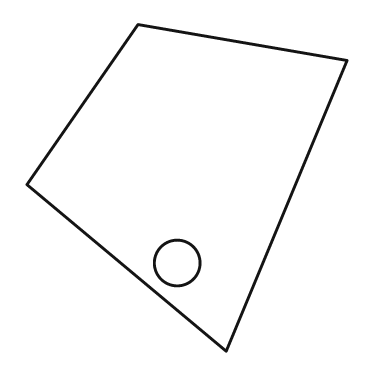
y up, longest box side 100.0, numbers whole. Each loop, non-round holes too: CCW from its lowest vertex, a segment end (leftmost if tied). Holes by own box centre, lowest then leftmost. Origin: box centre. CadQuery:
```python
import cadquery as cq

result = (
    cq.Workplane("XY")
    .moveTo(12.0, -50.0)
    .lineTo(49.0, 39.0)
    .lineTo(-15.0, 50.0)
    .lineTo(-49.0, 1.0)
    .close()
    .moveTo(-3.0, -23.0)
    .circle(7.0)
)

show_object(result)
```